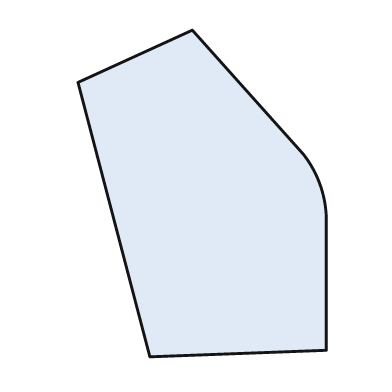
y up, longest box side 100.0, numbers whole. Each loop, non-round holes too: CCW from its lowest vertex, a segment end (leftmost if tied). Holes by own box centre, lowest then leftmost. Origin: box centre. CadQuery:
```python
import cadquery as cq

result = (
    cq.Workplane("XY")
    .moveTo(-16.0, -50.0)
    .lineTo(38.0, -48.0)
    .lineTo(38.0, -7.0)
    .threePointArc((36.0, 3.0), (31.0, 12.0))
    .lineTo(-3.0, 50.0)
    .lineTo(-38.0, 34.0)
    .close()
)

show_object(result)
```